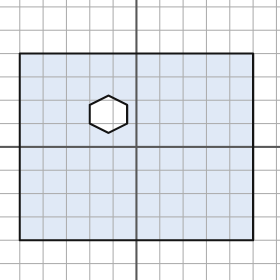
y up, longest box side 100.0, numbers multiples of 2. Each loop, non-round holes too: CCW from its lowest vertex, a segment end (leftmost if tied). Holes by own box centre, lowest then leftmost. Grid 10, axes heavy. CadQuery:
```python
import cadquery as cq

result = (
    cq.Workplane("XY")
    .moveTo(-50.0, -40.0)
    .lineTo(50.0, -40.0)
    .lineTo(50.0, 40.0)
    .lineTo(-50.0, 40.0)
    .close()
    .moveTo(-12.0, 6.0)
    .lineTo(-4.0, 10.0)
    .lineTo(-4.0, 18.0)
    .lineTo(-12.0, 22.0)
    .lineTo(-20.0, 18.0)
    .lineTo(-20.0, 10.0)
    .close()
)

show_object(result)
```